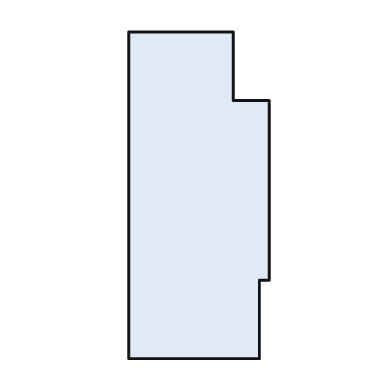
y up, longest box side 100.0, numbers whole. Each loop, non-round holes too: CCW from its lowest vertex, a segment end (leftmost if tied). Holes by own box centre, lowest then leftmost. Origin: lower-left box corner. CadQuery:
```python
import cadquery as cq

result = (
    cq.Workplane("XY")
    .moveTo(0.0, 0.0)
    .lineTo(40.0, 0.0)
    .lineTo(40.0, 24.0)
    .lineTo(43.0, 24.0)
    .lineTo(43.0, 79.0)
    .lineTo(32.0, 79.0)
    .lineTo(32.0, 100.0)
    .lineTo(0.0, 100.0)
    .close()
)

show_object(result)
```